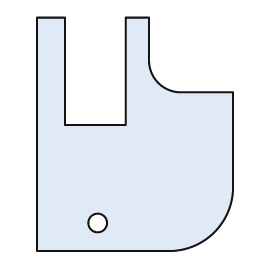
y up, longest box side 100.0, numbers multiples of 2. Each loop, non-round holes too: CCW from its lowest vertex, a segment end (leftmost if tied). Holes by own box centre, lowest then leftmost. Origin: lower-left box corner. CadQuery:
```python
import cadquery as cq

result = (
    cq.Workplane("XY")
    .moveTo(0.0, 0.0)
    .lineTo(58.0, 0.0)
    .threePointArc((76.0, 8.0), (84.0, 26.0))
    .lineTo(84.0, 68.0)
    .lineTo(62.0, 68.0)
    .threePointArc((52.0, 72.0), (48.0, 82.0))
    .lineTo(48.0, 100.0)
    .lineTo(38.0, 100.0)
    .lineTo(38.0, 54.0)
    .lineTo(12.0, 54.0)
    .lineTo(12.0, 100.0)
    .lineTo(0.0, 100.0)
    .close()
    .moveTo(26.0, 12.0)
    .circle(4.0)
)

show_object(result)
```